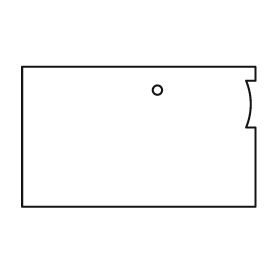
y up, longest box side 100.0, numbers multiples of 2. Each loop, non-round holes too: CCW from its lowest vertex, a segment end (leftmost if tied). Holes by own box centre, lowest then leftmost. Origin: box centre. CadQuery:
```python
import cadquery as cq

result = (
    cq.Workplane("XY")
    .moveTo(-50.0, -30.0)
    .lineTo(50.0, -30.0)
    .lineTo(50.0, 4.0)
    .lineTo(46.0, 4.0)
    .threePointArc((48.0, 14.0), (46.0, 24.0))
    .lineTo(50.0, 24.0)
    .lineTo(50.0, 30.0)
    .lineTo(-50.0, 30.0)
    .close()
    .moveTo(8.0, 20.0)
    .circle(2.0)
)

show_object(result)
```